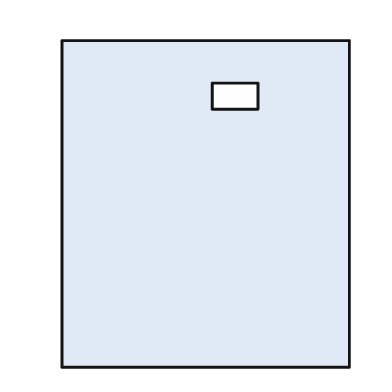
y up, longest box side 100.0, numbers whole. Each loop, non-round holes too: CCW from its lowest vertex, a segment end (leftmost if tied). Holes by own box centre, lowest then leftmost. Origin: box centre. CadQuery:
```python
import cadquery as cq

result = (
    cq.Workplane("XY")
    .moveTo(-44.0, -50.0)
    .lineTo(44.0, -50.0)
    .lineTo(44.0, 50.0)
    .lineTo(-44.0, 50.0)
    .close()
    .moveTo(2.0, 29.0)
    .lineTo(16.0, 29.0)
    .lineTo(16.0, 37.0)
    .lineTo(2.0, 37.0)
    .close()
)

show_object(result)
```